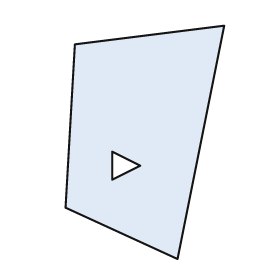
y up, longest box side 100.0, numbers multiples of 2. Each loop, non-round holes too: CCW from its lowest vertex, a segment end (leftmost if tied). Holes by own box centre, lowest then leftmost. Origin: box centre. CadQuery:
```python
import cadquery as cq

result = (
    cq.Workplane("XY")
    .moveTo(14.0, -50.0)
    .lineTo(34.0, 50.0)
    .lineTo(-30.0, 42.0)
    .lineTo(-34.0, -28.0)
    .close()
    .moveTo(-14.0, -16.0)
    .lineTo(-2.0, -10.0)
    .lineTo(-14.0, -4.0)
    .close()
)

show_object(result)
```